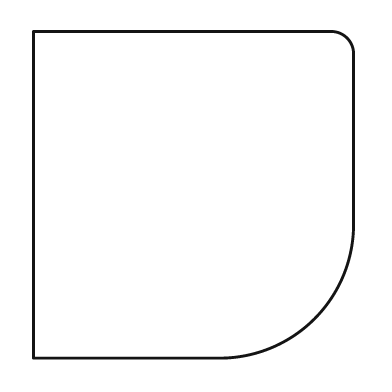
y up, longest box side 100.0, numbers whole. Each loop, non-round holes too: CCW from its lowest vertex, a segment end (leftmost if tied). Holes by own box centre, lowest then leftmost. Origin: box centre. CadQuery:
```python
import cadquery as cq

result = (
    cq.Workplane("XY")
    .moveTo(-49.0, -50.0)
    .lineTo(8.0, -50.0)
    .threePointArc((37.0, -38.0), (49.0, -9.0))
    .lineTo(49.0, 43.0)
    .threePointArc((47.0, 48.0), (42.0, 50.0))
    .lineTo(-49.0, 50.0)
    .close()
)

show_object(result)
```